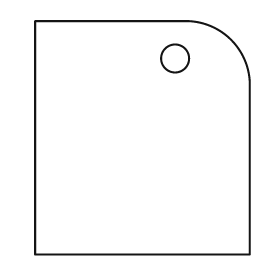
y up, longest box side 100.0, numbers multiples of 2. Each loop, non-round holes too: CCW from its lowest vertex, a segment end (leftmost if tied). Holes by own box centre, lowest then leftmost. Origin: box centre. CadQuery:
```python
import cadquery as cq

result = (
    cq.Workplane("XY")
    .moveTo(-46.0, -50.0)
    .lineTo(46.0, -50.0)
    .lineTo(46.0, 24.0)
    .threePointArc((38.0, 42.0), (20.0, 50.0))
    .lineTo(-46.0, 50.0)
    .close()
    .moveTo(14.0, 34.0)
    .circle(6.0)
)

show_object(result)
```